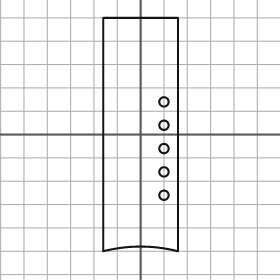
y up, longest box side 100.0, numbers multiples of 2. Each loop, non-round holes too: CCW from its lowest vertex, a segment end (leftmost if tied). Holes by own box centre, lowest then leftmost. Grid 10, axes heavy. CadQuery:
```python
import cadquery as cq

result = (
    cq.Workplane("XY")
    .moveTo(-16.0, -50.0)
    .threePointArc((0.0, -48.0), (16.0, -50.0))
    .lineTo(16.0, 50.0)
    .lineTo(-16.0, 50.0)
    .close()
    .moveTo(10.0, -26.0)
    .circle(2.0)
    .moveTo(10.0, -16.0)
    .circle(2.0)
    .moveTo(10.0, -6.0)
    .circle(2.0)
    .moveTo(10.0, 4.0)
    .circle(2.0)
    .moveTo(10.0, 14.0)
    .circle(2.0)
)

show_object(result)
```